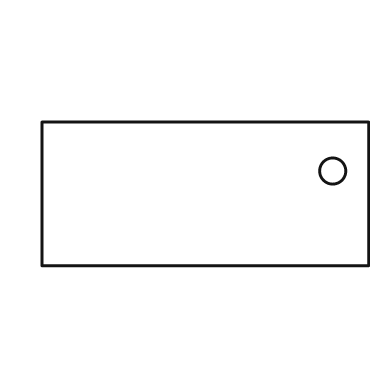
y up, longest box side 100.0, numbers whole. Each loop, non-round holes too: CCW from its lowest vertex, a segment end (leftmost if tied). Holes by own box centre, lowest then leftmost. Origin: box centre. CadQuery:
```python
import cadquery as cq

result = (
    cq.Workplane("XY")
    .moveTo(-50.0, -22.0)
    .lineTo(50.0, -22.0)
    .lineTo(50.0, 22.0)
    .lineTo(-50.0, 22.0)
    .close()
    .moveTo(39.0, 7.0)
    .circle(4.0)
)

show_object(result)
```